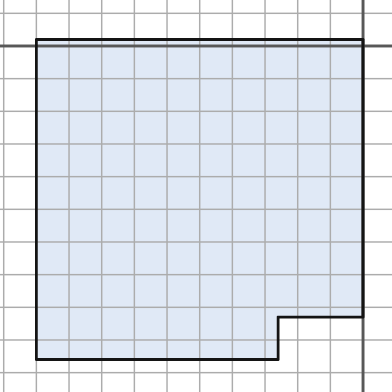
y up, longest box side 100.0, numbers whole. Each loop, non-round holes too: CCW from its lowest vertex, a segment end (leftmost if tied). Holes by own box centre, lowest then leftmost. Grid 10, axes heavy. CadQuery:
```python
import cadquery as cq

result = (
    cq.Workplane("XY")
    .moveTo(-100.0, -96.0)
    .lineTo(-26.0, -96.0)
    .lineTo(-26.0, -83.0)
    .lineTo(0.0, -83.0)
    .lineTo(0.0, 2.0)
    .lineTo(-100.0, 2.0)
    .close()
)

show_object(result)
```